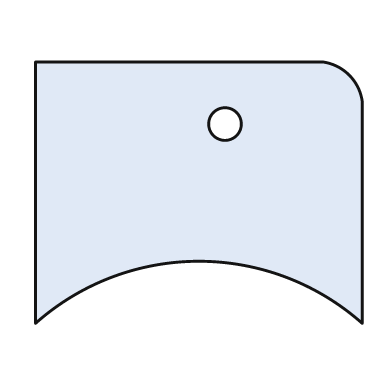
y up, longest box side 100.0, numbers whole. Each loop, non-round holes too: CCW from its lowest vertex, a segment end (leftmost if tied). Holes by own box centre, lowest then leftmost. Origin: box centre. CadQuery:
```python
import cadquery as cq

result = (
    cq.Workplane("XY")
    .moveTo(-50.0, -40.0)
    .threePointArc((0.0, -21.0), (50.0, -40.0))
    .lineTo(50.0, 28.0)
    .threePointArc((46.0, 36.0), (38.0, 40.0))
    .lineTo(-50.0, 40.0)
    .close()
    .moveTo(8.0, 21.0)
    .circle(5.0)
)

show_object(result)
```